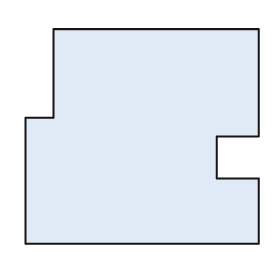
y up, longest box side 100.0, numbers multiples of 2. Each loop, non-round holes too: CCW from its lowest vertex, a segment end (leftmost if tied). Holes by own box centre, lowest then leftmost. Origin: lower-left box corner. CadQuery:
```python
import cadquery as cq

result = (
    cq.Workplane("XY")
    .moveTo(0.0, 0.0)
    .lineTo(100.0, 0.0)
    .lineTo(100.0, 28.0)
    .lineTo(82.0, 28.0)
    .lineTo(82.0, 46.0)
    .lineTo(100.0, 46.0)
    .lineTo(100.0, 92.0)
    .lineTo(12.0, 92.0)
    .lineTo(12.0, 54.0)
    .lineTo(0.0, 54.0)
    .close()
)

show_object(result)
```